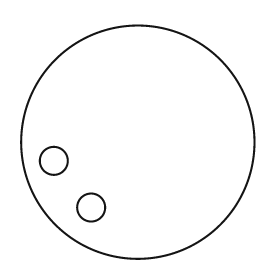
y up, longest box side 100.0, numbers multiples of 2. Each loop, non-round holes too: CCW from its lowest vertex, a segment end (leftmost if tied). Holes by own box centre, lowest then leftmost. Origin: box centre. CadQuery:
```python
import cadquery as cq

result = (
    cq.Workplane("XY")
    .moveTo(0.0, 0.0)
    .circle(50.0)
    .moveTo(-20.0, -28.0)
    .circle(6.0)
    .moveTo(-36.0, -8.0)
    .circle(6.0)
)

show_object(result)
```